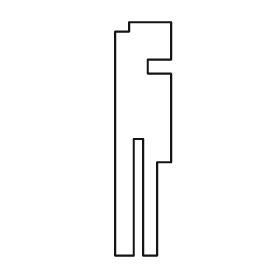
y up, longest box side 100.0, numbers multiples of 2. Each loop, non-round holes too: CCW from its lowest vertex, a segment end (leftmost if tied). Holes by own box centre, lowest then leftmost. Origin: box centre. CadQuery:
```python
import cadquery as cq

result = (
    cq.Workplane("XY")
    .moveTo(-12.0, -50.0)
    .lineTo(-4.0, -50.0)
    .lineTo(-4.0, 0.0)
    .lineTo(0.0, 0.0)
    .lineTo(0.0, -50.0)
    .lineTo(6.0, -50.0)
    .lineTo(6.0, -10.0)
    .lineTo(12.0, -10.0)
    .lineTo(12.0, 28.0)
    .lineTo(2.0, 28.0)
    .lineTo(2.0, 34.0)
    .lineTo(12.0, 34.0)
    .lineTo(12.0, 50.0)
    .lineTo(-6.0, 50.0)
    .lineTo(-6.0, 46.0)
    .lineTo(-12.0, 46.0)
    .close()
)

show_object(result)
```